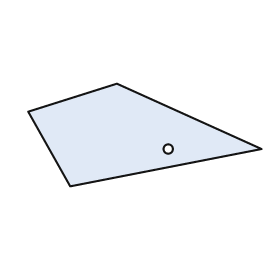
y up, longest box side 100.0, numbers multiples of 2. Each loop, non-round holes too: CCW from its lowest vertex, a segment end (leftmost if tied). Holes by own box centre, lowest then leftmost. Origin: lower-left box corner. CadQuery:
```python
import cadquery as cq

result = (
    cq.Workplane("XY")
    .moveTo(18.0, 0.0)
    .lineTo(100.0, 16.0)
    .lineTo(38.0, 44.0)
    .lineTo(0.0, 32.0)
    .close()
    .moveTo(60.0, 16.0)
    .circle(2.0)
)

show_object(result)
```